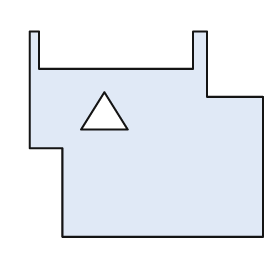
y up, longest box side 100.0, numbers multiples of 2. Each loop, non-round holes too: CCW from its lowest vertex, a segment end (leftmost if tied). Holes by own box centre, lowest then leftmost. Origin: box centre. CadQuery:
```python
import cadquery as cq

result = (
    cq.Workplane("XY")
    .moveTo(-36.0, -44.0)
    .lineTo(50.0, -44.0)
    .lineTo(50.0, 16.0)
    .lineTo(26.0, 16.0)
    .lineTo(26.0, 44.0)
    .lineTo(20.0, 44.0)
    .lineTo(20.0, 28.0)
    .lineTo(-46.0, 28.0)
    .lineTo(-46.0, 44.0)
    .lineTo(-50.0, 44.0)
    .lineTo(-50.0, -6.0)
    .lineTo(-36.0, -6.0)
    .close()
    .moveTo(-28.0, 2.0)
    .lineTo(-8.0, 2.0)
    .lineTo(-18.0, 18.0)
    .close()
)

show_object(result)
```